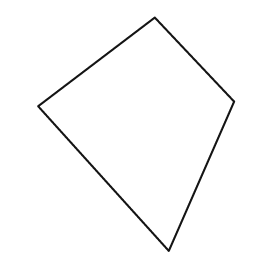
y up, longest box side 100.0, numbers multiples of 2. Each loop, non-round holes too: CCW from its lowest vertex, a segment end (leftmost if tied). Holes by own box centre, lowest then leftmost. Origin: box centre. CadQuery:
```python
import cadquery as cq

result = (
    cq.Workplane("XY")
    .moveTo(14.0, -50.0)
    .lineTo(42.0, 14.0)
    .lineTo(8.0, 50.0)
    .lineTo(-42.0, 12.0)
    .close()
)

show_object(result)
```